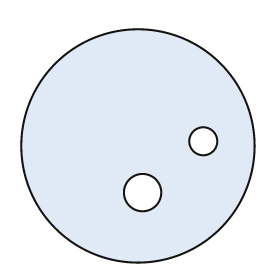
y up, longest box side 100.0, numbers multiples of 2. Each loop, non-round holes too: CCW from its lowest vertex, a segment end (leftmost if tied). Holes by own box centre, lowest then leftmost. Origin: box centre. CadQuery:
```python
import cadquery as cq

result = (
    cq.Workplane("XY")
    .moveTo(0.0, 0.0)
    .circle(50.0)
    .moveTo(2.0, -20.0)
    .circle(8.0)
    .moveTo(28.0, 2.0)
    .circle(6.0)
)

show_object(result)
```